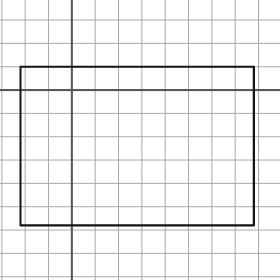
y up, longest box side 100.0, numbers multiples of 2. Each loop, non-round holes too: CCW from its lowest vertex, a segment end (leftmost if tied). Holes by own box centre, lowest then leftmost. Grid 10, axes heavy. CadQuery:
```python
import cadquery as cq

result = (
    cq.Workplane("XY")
    .moveTo(-22.0, -58.0)
    .lineTo(78.0, -58.0)
    .lineTo(78.0, 10.0)
    .lineTo(-22.0, 10.0)
    .close()
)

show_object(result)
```